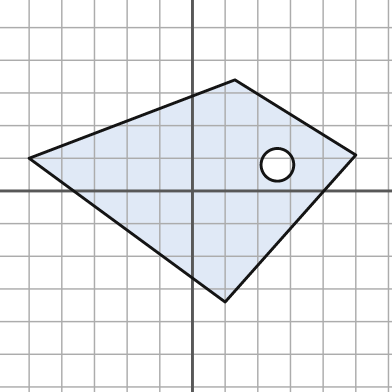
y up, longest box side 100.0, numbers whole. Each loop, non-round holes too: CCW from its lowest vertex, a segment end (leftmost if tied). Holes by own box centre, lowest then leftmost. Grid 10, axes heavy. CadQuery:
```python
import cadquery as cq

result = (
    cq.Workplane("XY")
    .moveTo(10.0, -34.0)
    .lineTo(50.0, 11.0)
    .lineTo(13.0, 34.0)
    .lineTo(-50.0, 10.0)
    .close()
    .moveTo(26.0, 8.0)
    .circle(5.0)
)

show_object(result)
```